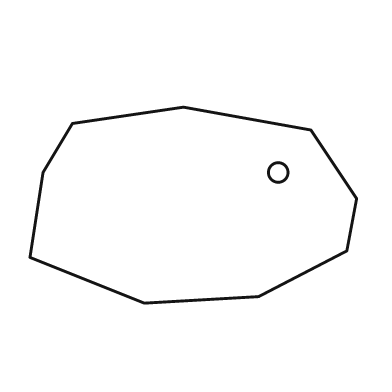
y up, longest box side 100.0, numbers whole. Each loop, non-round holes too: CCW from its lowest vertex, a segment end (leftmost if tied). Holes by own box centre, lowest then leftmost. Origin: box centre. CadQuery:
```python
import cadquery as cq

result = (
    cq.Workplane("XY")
    .moveTo(-15.0, -30.0)
    .lineTo(20.0, -28.0)
    .lineTo(47.0, -14.0)
    .lineTo(50.0, 2.0)
    .lineTo(36.0, 23.0)
    .lineTo(-3.0, 30.0)
    .lineTo(-37.0, 25.0)
    .lineTo(-46.0, 10.0)
    .lineTo(-50.0, -16.0)
    .close()
    .moveTo(26.0, 10.0)
    .circle(3.0)
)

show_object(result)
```